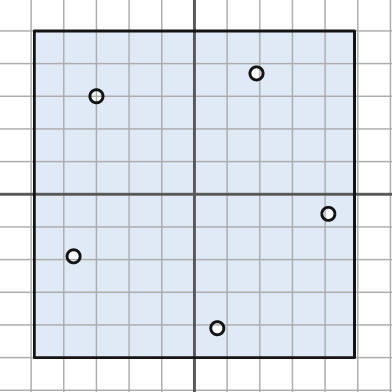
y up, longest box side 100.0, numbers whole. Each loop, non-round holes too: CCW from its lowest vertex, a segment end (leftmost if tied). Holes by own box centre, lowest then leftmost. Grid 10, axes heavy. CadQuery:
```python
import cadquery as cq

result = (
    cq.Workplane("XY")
    .moveTo(-49.0, -50.0)
    .lineTo(49.0, -50.0)
    .lineTo(49.0, 50.0)
    .lineTo(-49.0, 50.0)
    .close()
    .moveTo(7.0, -41.0)
    .circle(2.0)
    .moveTo(-37.0, -19.0)
    .circle(2.0)
    .moveTo(41.0, -6.0)
    .circle(2.0)
    .moveTo(-30.0, 30.0)
    .circle(2.0)
    .moveTo(19.0, 37.0)
    .circle(2.0)
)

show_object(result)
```